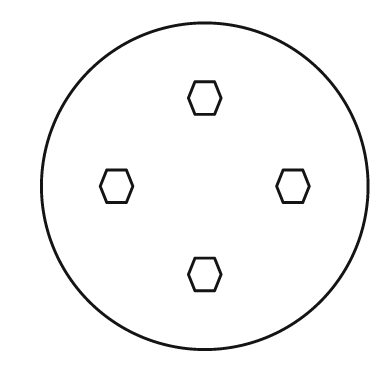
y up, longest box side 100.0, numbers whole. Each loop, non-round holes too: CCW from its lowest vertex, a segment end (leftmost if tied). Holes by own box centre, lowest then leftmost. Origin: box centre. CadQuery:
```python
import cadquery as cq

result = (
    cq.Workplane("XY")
    .moveTo(0.0, 0.0)
    .circle(50.0)
    .moveTo(-3.0, -32.0)
    .lineTo(3.0, -32.0)
    .lineTo(5.0, -27.0)
    .lineTo(3.0, -22.0)
    .lineTo(-3.0, -22.0)
    .lineTo(-5.0, -27.0)
    .close()
    .moveTo(-30.0, -5.0)
    .lineTo(-24.0, -5.0)
    .lineTo(-22.0, 0.0)
    .lineTo(-24.0, 5.0)
    .lineTo(-30.0, 5.0)
    .lineTo(-32.0, 0.0)
    .close()
    .moveTo(24.0, -5.0)
    .lineTo(30.0, -5.0)
    .lineTo(32.0, 0.0)
    .lineTo(30.0, 5.0)
    .lineTo(24.0, 5.0)
    .lineTo(22.0, 0.0)
    .close()
    .moveTo(-3.0, 22.0)
    .lineTo(3.0, 22.0)
    .lineTo(5.0, 27.0)
    .lineTo(3.0, 32.0)
    .lineTo(-3.0, 32.0)
    .lineTo(-5.0, 27.0)
    .close()
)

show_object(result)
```